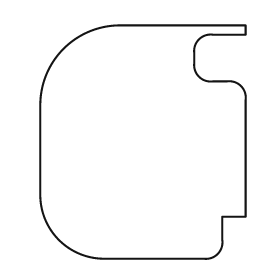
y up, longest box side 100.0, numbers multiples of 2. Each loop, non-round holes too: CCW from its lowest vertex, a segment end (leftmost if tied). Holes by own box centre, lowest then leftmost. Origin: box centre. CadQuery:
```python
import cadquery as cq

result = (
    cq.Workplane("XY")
    .moveTo(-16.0, -50.0)
    .lineTo(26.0, -50.0)
    .threePointArc((32.0, -48.0), (34.0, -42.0))
    .lineTo(34.0, -32.0)
    .lineTo(44.0, -32.0)
    .lineTo(44.0, 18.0)
    .threePointArc((42.0, 24.0), (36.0, 26.0))
    .lineTo(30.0, 26.0)
    .threePointArc((24.0, 28.0), (22.0, 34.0))
    .lineTo(22.0, 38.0)
    .threePointArc((24.0, 44.0), (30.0, 46.0))
    .lineTo(44.0, 46.0)
    .lineTo(44.0, 50.0)
    .lineTo(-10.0, 50.0)
    .threePointArc((-34.0, 40.0), (-44.0, 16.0))
    .lineTo(-44.0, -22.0)
    .threePointArc((-36.0, -42.0), (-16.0, -50.0))
    .close()
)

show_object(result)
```